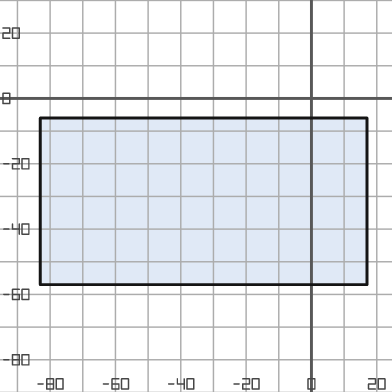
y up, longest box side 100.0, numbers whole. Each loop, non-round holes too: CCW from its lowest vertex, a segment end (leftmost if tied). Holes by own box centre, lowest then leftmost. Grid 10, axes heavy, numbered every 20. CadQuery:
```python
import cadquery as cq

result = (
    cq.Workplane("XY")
    .moveTo(-83.0, -57.0)
    .lineTo(17.0, -57.0)
    .lineTo(17.0, -6.0)
    .lineTo(-83.0, -6.0)
    .close()
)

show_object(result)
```